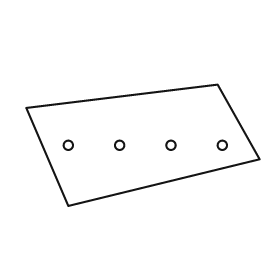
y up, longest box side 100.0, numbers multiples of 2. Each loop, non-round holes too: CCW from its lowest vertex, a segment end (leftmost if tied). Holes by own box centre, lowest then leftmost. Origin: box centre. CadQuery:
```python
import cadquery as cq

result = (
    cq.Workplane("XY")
    .moveTo(-32.0, -26.0)
    .lineTo(50.0, -6.0)
    .lineTo(32.0, 26.0)
    .lineTo(-50.0, 16.0)
    .close()
    .moveTo(-32.0, 0.0)
    .circle(2.0)
    .moveTo(-10.0, 0.0)
    .circle(2.0)
    .moveTo(12.0, 0.0)
    .circle(2.0)
    .moveTo(34.0, 0.0)
    .circle(2.0)
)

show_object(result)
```